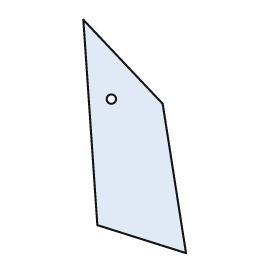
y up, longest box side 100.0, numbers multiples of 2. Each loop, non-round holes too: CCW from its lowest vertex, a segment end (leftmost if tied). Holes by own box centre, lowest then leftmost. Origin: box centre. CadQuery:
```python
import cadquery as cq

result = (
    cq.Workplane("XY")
    .moveTo(22.0, -50.0)
    .lineTo(12.0, 14.0)
    .lineTo(-22.0, 50.0)
    .lineTo(-16.0, -38.0)
    .close()
    .moveTo(-10.0, 16.0)
    .circle(2.0)
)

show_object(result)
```